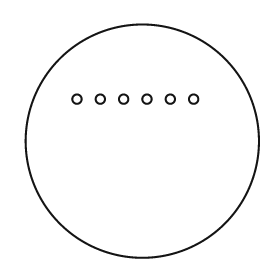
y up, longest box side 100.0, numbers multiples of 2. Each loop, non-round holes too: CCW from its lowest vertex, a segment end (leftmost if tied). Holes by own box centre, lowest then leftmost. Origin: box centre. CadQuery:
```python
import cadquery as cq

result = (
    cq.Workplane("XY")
    .moveTo(0.0, 0.0)
    .circle(50.0)
    .moveTo(-28.0, 18.0)
    .circle(2.0)
    .moveTo(-18.0, 18.0)
    .circle(2.0)
    .moveTo(-8.0, 18.0)
    .circle(2.0)
    .moveTo(2.0, 18.0)
    .circle(2.0)
    .moveTo(12.0, 18.0)
    .circle(2.0)
    .moveTo(22.0, 18.0)
    .circle(2.0)
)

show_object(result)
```